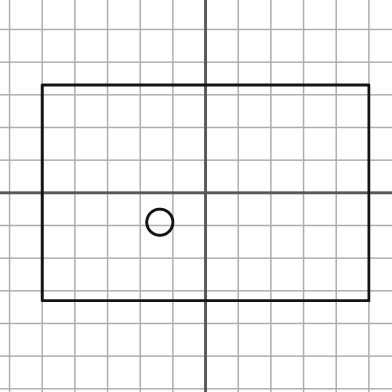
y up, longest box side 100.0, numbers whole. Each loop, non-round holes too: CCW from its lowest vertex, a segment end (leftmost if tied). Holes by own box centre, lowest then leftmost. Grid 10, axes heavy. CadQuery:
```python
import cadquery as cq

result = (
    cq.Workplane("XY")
    .moveTo(-50.0, -33.0)
    .lineTo(50.0, -33.0)
    .lineTo(50.0, 33.0)
    .lineTo(-50.0, 33.0)
    .close()
    .moveTo(-14.0, -9.0)
    .circle(4.0)
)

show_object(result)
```